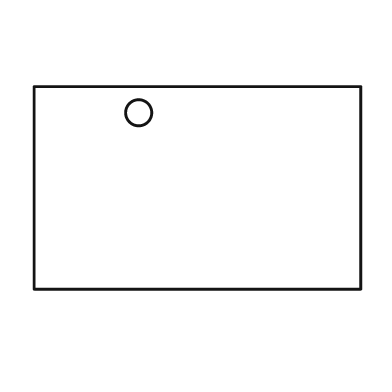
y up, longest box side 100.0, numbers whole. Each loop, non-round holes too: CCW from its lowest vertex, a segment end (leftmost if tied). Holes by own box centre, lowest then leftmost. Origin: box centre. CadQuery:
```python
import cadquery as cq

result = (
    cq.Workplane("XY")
    .moveTo(-50.0, -31.0)
    .lineTo(50.0, -31.0)
    .lineTo(50.0, 31.0)
    .lineTo(-50.0, 31.0)
    .close()
    .moveTo(-18.0, 23.0)
    .circle(4.0)
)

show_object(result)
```